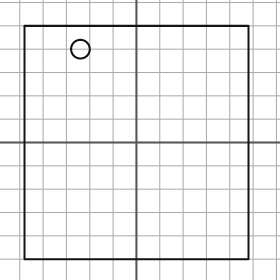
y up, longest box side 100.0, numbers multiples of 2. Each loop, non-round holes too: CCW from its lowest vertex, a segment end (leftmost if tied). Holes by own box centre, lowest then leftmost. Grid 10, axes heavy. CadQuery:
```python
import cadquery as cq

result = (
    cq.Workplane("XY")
    .moveTo(-48.0, -50.0)
    .lineTo(48.0, -50.0)
    .lineTo(48.0, 50.0)
    .lineTo(-48.0, 50.0)
    .close()
    .moveTo(-24.0, 40.0)
    .circle(4.0)
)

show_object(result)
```